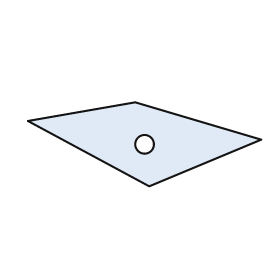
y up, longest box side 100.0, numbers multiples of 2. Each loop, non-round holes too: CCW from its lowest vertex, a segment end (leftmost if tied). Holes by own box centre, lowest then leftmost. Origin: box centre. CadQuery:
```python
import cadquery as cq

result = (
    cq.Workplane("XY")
    .moveTo(2.0, -18.0)
    .lineTo(50.0, 2.0)
    .lineTo(-4.0, 18.0)
    .lineTo(-50.0, 10.0)
    .close()
    .moveTo(0.0, 0.0)
    .circle(4.0)
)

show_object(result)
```